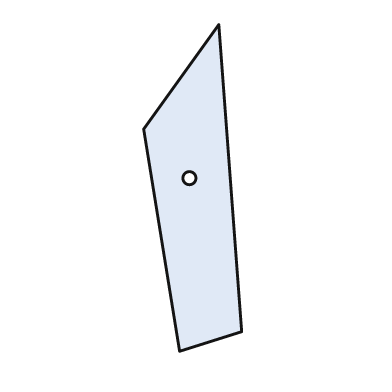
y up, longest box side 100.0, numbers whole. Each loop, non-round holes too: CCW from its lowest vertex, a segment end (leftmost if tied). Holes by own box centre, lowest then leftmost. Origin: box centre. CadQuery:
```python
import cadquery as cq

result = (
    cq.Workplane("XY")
    .moveTo(-4.0, -50.0)
    .lineTo(15.0, -44.0)
    .lineTo(8.0, 50.0)
    .lineTo(-15.0, 18.0)
    .close()
    .moveTo(-1.0, 3.0)
    .circle(2.0)
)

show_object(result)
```